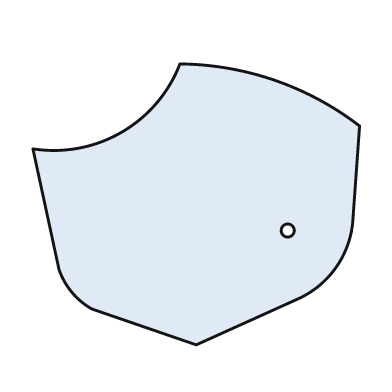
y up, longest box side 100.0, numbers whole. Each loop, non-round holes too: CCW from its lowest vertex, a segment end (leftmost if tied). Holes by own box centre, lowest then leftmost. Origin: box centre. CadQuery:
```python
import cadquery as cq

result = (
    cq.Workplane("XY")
    .moveTo(0.0, -43.0)
    .lineTo(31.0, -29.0)
    .threePointArc((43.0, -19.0), (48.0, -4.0))
    .lineTo(50.0, 24.0)
    .threePointArc((24.0, 38.0), (-5.0, 43.0))
    .threePointArc((-23.0, 22.0), (-50.0, 17.0))
    .lineTo(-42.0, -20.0)
    .threePointArc((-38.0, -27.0), (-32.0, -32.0))
    .close()
    .moveTo(28.0, -8.0)
    .circle(2.0)
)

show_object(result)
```